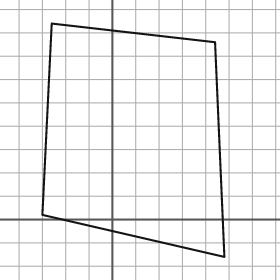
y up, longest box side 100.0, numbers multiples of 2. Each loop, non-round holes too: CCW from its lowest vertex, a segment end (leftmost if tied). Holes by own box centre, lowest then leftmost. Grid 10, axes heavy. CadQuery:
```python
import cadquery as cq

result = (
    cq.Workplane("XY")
    .moveTo(48.0, -16.0)
    .lineTo(44.0, 76.0)
    .lineTo(-26.0, 84.0)
    .lineTo(-30.0, 2.0)
    .close()
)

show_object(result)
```